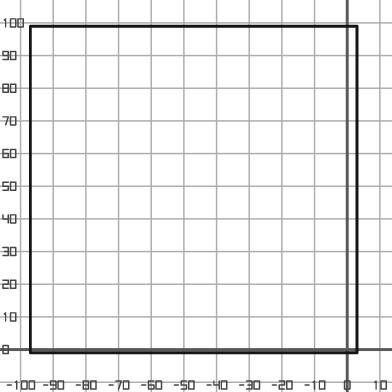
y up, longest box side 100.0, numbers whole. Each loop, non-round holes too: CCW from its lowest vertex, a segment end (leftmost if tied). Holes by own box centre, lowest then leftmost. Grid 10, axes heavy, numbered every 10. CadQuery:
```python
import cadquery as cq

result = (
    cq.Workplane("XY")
    .moveTo(-97.0, -1.0)
    .lineTo(3.0, -1.0)
    .lineTo(3.0, 99.0)
    .lineTo(-97.0, 99.0)
    .close()
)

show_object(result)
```